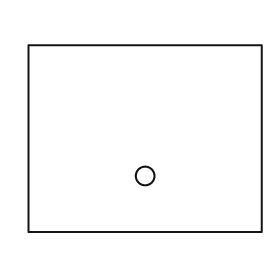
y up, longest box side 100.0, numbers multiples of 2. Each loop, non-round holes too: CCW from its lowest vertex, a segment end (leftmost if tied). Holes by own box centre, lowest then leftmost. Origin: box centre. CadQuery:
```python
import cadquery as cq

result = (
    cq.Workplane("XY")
    .moveTo(-50.0, -40.0)
    .lineTo(50.0, -40.0)
    .lineTo(50.0, 40.0)
    .lineTo(-50.0, 40.0)
    .close()
    .moveTo(0.0, -16.0)
    .circle(4.0)
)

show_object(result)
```